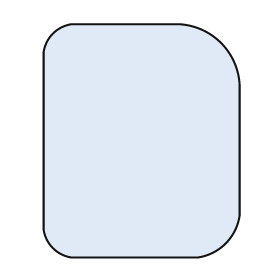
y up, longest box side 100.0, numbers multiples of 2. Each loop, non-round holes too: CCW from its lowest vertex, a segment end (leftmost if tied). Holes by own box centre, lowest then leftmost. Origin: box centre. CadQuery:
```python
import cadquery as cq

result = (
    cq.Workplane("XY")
    .moveTo(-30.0, -50.0)
    .lineTo(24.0, -50.0)
    .threePointArc((36.0, -44.0), (42.0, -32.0))
    .lineTo(42.0, 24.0)
    .threePointArc((34.0, 42.0), (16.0, 50.0))
    .lineTo(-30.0, 50.0)
    .threePointArc((-38.0, 46.0), (-42.0, 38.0))
    .lineTo(-42.0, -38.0)
    .threePointArc((-38.0, -46.0), (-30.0, -50.0))
    .close()
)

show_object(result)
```